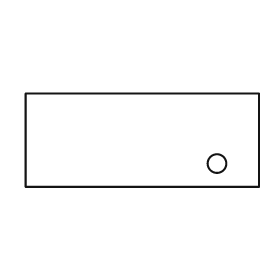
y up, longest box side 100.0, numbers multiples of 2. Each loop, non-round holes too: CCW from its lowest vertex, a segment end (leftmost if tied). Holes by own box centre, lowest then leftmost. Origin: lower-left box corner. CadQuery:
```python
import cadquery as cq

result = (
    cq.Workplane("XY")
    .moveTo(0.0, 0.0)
    .lineTo(100.0, 0.0)
    .lineTo(100.0, 40.0)
    .lineTo(0.0, 40.0)
    .close()
    .moveTo(82.0, 10.0)
    .circle(4.0)
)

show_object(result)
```